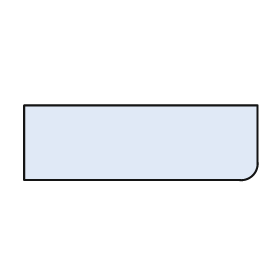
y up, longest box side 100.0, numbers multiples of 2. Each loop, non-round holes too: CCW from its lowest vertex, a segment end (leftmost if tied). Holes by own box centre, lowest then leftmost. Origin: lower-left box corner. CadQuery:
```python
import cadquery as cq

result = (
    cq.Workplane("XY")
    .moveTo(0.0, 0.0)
    .lineTo(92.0, 0.0)
    .threePointArc((98.0, 2.0), (100.0, 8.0))
    .lineTo(100.0, 32.0)
    .lineTo(0.0, 32.0)
    .close()
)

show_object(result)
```